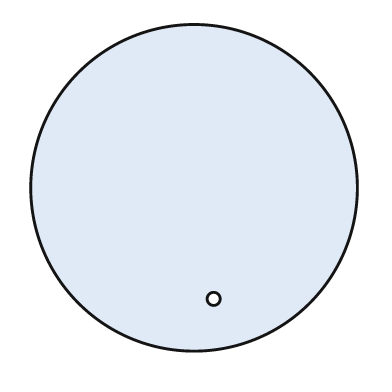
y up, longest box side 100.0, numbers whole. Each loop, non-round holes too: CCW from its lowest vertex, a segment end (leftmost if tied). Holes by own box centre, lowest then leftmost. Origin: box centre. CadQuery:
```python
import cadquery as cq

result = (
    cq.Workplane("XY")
    .moveTo(0.0, 0.0)
    .circle(50.0)
    .moveTo(6.0, -34.0)
    .circle(2.0)
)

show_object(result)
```